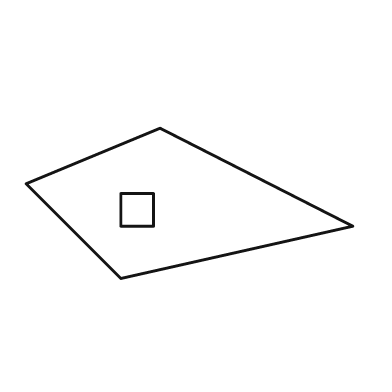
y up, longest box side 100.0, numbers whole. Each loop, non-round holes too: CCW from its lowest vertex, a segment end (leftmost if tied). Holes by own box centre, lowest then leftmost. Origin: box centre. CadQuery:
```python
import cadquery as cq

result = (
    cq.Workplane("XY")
    .moveTo(-21.0, -23.0)
    .lineTo(50.0, -7.0)
    .lineTo(-9.0, 23.0)
    .lineTo(-50.0, 6.0)
    .close()
    .moveTo(-21.0, -7.0)
    .lineTo(-11.0, -7.0)
    .lineTo(-11.0, 3.0)
    .lineTo(-21.0, 3.0)
    .close()
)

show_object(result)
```